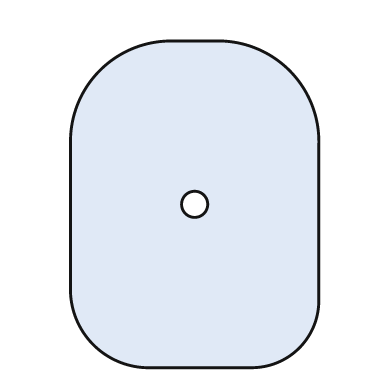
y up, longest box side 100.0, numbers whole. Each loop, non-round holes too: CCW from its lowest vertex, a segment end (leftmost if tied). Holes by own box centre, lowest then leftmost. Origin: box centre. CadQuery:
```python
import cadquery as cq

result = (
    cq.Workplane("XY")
    .moveTo(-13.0, -50.0)
    .lineTo(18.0, -50.0)
    .threePointArc((32.0, -44.0), (38.0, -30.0))
    .lineTo(38.0, 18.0)
    .threePointArc((29.0, 41.0), (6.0, 50.0))
    .lineTo(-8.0, 50.0)
    .threePointArc((-29.0, 41.0), (-38.0, 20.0))
    .lineTo(-38.0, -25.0)
    .threePointArc((-31.0, -43.0), (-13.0, -50.0))
    .close()
    .moveTo(0.0, 0.0)
    .circle(4.0)
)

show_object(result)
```